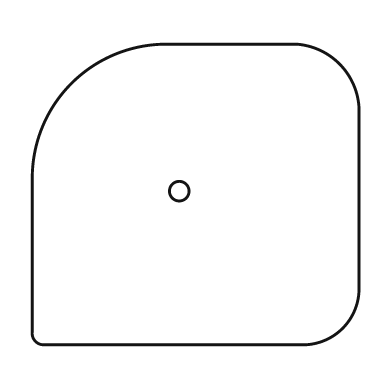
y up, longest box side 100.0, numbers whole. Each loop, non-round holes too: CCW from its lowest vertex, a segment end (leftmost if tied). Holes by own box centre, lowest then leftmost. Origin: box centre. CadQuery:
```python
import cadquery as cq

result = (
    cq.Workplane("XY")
    .moveTo(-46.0, -46.0)
    .lineTo(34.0, -46.0)
    .threePointArc((45.0, -41.0), (50.0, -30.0))
    .lineTo(50.0, 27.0)
    .threePointArc((44.0, 40.0), (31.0, 46.0))
    .lineTo(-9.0, 46.0)
    .threePointArc((-38.0, 34.0), (-50.0, 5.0))
    .lineTo(-50.0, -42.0)
    .threePointArc((-49.0, -45.0), (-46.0, -46.0))
    .close()
    .moveTo(-5.0, 1.0)
    .circle(3.0)
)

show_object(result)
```